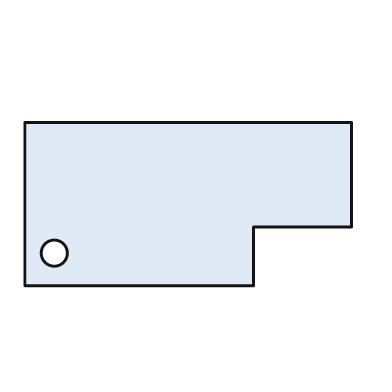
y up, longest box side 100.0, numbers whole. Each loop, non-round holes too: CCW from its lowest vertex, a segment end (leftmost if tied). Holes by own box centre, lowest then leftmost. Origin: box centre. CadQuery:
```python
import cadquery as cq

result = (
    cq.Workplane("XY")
    .moveTo(-50.0, -25.0)
    .lineTo(20.0, -25.0)
    .lineTo(20.0, -7.0)
    .lineTo(50.0, -7.0)
    .lineTo(50.0, 25.0)
    .lineTo(-50.0, 25.0)
    .close()
    .moveTo(-41.0, -15.0)
    .circle(4.0)
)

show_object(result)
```